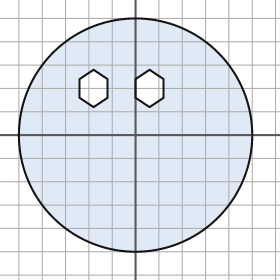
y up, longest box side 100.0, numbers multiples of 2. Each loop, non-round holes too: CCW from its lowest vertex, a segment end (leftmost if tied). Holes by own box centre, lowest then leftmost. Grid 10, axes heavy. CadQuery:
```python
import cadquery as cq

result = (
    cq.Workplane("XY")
    .moveTo(0.0, 0.0)
    .circle(50.0)
    .moveTo(-18.0, 12.0)
    .lineTo(-12.0, 16.0)
    .lineTo(-12.0, 24.0)
    .lineTo(-18.0, 28.0)
    .lineTo(-24.0, 24.0)
    .lineTo(-24.0, 16.0)
    .close()
    .moveTo(6.0, 12.0)
    .lineTo(12.0, 16.0)
    .lineTo(12.0, 24.0)
    .lineTo(6.0, 28.0)
    .lineTo(0.0, 24.0)
    .lineTo(0.0, 16.0)
    .close()
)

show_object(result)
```